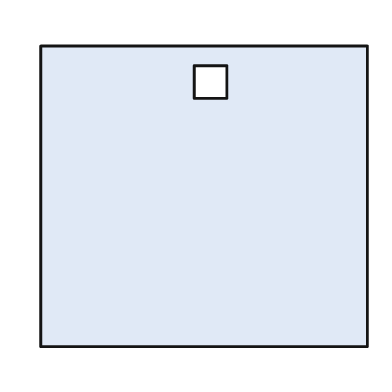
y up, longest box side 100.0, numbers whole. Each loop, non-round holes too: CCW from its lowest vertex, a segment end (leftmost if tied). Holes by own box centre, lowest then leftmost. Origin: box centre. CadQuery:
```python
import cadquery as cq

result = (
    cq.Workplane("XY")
    .moveTo(-50.0, -46.0)
    .lineTo(50.0, -46.0)
    .lineTo(50.0, 46.0)
    .lineTo(-50.0, 46.0)
    .close()
    .moveTo(-3.0, 30.0)
    .lineTo(7.0, 30.0)
    .lineTo(7.0, 40.0)
    .lineTo(-3.0, 40.0)
    .close()
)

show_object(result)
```